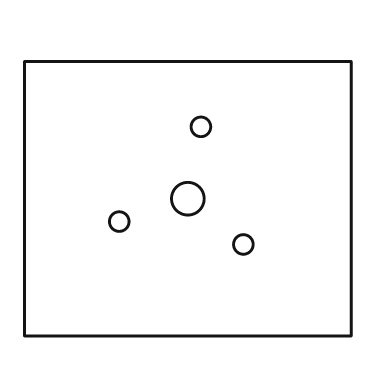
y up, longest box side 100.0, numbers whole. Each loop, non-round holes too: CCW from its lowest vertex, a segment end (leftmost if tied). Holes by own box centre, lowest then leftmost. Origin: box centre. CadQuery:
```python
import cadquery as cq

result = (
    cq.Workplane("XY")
    .moveTo(-50.0, -42.0)
    .lineTo(50.0, -42.0)
    .lineTo(50.0, 42.0)
    .lineTo(-50.0, 42.0)
    .close()
    .moveTo(17.0, -14.0)
    .circle(3.0)
    .moveTo(-21.0, -7.0)
    .circle(3.0)
    .moveTo(0.0, 0.0)
    .circle(5.0)
    .moveTo(4.0, 22.0)
    .circle(3.0)
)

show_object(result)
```